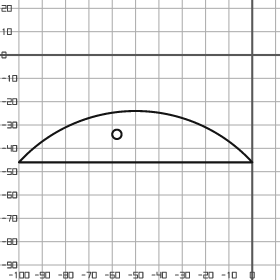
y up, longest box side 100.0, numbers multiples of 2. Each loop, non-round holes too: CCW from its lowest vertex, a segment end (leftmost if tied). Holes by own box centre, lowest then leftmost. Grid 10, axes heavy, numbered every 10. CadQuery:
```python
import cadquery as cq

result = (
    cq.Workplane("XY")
    .moveTo(-100.0, -46.0)
    .lineTo(0.0, -46.0)
    .threePointArc((-50.0, -24.0), (-100.0, -46.0))
    .close()
    .moveTo(-58.0, -34.0)
    .circle(2.0)
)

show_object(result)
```